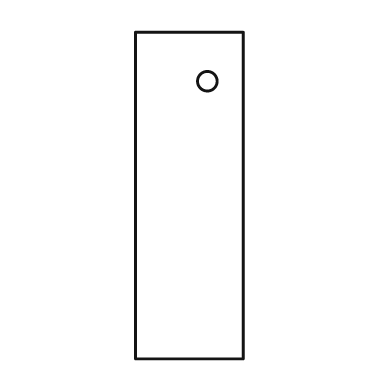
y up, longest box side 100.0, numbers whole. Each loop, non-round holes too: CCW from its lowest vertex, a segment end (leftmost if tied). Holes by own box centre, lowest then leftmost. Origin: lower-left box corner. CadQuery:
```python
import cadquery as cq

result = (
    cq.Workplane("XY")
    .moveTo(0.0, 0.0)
    .lineTo(33.0, 0.0)
    .lineTo(33.0, 100.0)
    .lineTo(0.0, 100.0)
    .close()
    .moveTo(22.0, 85.0)
    .circle(3.0)
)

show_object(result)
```